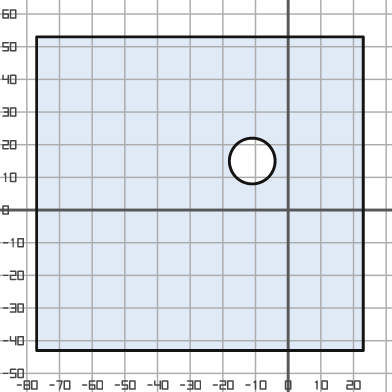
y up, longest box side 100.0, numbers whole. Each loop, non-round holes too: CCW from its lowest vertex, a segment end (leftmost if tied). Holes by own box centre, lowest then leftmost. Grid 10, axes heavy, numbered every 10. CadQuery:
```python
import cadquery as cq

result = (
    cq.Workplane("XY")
    .moveTo(-77.0, -43.0)
    .lineTo(23.0, -43.0)
    .lineTo(23.0, 53.0)
    .lineTo(-77.0, 53.0)
    .close()
    .moveTo(-11.0, 15.0)
    .circle(7.0)
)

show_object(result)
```